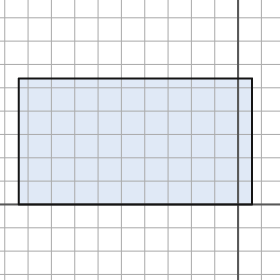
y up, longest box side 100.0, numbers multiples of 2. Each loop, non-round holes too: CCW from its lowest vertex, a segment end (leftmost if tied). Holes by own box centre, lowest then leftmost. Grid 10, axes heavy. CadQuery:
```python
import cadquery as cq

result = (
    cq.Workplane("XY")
    .moveTo(-94.0, 0.0)
    .lineTo(6.0, 0.0)
    .lineTo(6.0, 54.0)
    .lineTo(-94.0, 54.0)
    .close()
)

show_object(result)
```